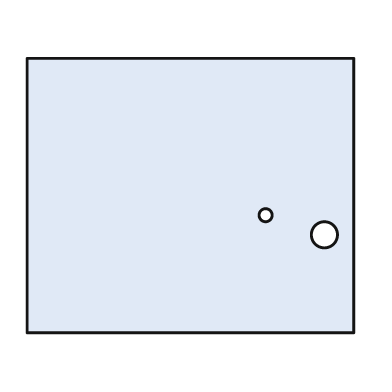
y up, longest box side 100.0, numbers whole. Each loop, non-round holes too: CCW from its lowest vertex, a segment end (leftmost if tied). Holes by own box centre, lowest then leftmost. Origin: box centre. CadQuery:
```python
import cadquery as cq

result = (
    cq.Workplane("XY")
    .moveTo(-50.0, -42.0)
    .lineTo(50.0, -42.0)
    .lineTo(50.0, 42.0)
    .lineTo(-50.0, 42.0)
    .close()
    .moveTo(41.0, -12.0)
    .circle(4.0)
    .moveTo(23.0, -6.0)
    .circle(2.0)
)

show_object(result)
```